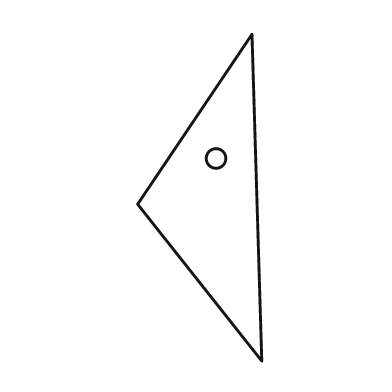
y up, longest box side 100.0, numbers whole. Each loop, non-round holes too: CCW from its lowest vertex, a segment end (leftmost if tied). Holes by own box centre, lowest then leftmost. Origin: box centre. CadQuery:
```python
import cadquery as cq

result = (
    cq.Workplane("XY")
    .moveTo(19.0, -50.0)
    .lineTo(16.0, 50.0)
    .lineTo(-19.0, -2.0)
    .close()
    .moveTo(5.0, 12.0)
    .circle(3.0)
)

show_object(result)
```